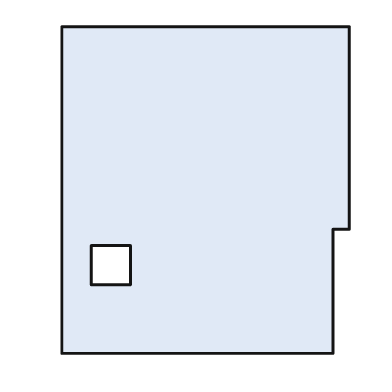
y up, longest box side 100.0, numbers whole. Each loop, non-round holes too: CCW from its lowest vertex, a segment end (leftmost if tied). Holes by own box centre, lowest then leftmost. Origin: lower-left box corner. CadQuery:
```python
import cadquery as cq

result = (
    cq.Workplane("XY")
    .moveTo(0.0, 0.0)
    .lineTo(83.0, 0.0)
    .lineTo(83.0, 38.0)
    .lineTo(88.0, 38.0)
    .lineTo(88.0, 100.0)
    .lineTo(0.0, 100.0)
    .close()
    .moveTo(9.0, 21.0)
    .lineTo(21.0, 21.0)
    .lineTo(21.0, 33.0)
    .lineTo(9.0, 33.0)
    .close()
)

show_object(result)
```